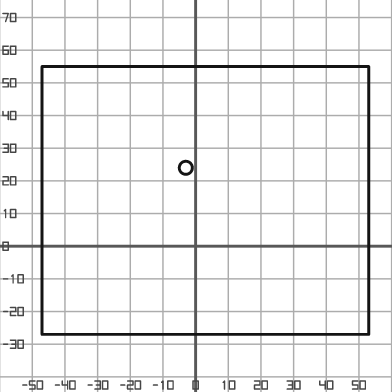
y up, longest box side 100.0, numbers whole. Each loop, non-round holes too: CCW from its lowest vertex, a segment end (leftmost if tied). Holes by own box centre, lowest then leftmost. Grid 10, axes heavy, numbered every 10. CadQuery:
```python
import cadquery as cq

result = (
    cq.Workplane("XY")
    .moveTo(-47.0, -27.0)
    .lineTo(53.0, -27.0)
    .lineTo(53.0, 55.0)
    .lineTo(-47.0, 55.0)
    .close()
    .moveTo(-3.0, 24.0)
    .circle(2.0)
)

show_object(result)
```